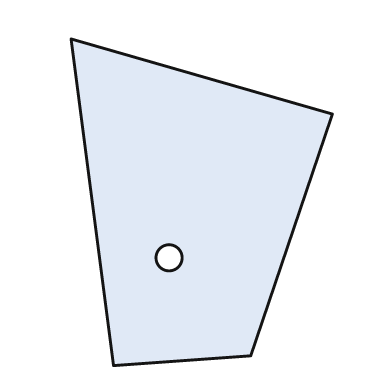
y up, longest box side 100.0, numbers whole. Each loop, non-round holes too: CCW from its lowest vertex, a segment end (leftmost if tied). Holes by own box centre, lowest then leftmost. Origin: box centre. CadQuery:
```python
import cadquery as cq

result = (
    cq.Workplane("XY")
    .moveTo(-27.0, -50.0)
    .lineTo(15.0, -47.0)
    .lineTo(40.0, 27.0)
    .lineTo(-40.0, 50.0)
    .close()
    .moveTo(-10.0, -17.0)
    .circle(4.0)
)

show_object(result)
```